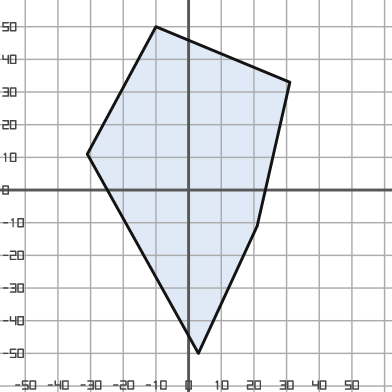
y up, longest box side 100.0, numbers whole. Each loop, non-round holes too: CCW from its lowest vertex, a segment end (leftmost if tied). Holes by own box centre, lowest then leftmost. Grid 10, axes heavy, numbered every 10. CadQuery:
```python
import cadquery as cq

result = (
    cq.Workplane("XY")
    .moveTo(3.0, -50.0)
    .lineTo(21.0, -11.0)
    .lineTo(31.0, 33.0)
    .lineTo(-10.0, 50.0)
    .lineTo(-31.0, 11.0)
    .close()
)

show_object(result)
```